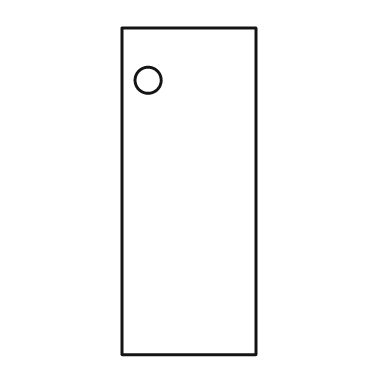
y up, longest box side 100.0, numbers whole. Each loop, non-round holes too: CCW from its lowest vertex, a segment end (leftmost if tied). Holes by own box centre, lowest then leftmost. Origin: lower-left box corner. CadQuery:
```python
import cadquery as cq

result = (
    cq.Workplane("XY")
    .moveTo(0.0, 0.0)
    .lineTo(41.0, 0.0)
    .lineTo(41.0, 100.0)
    .lineTo(0.0, 100.0)
    .close()
    .moveTo(8.0, 84.0)
    .circle(4.0)
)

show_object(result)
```